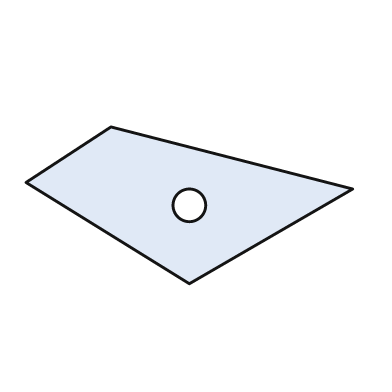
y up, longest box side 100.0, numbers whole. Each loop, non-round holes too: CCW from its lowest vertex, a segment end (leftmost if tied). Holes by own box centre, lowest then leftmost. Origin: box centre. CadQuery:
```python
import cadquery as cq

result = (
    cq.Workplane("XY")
    .moveTo(0.0, -24.0)
    .lineTo(50.0, 5.0)
    .lineTo(-24.0, 24.0)
    .lineTo(-50.0, 7.0)
    .close()
    .moveTo(0.0, 0.0)
    .circle(5.0)
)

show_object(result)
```